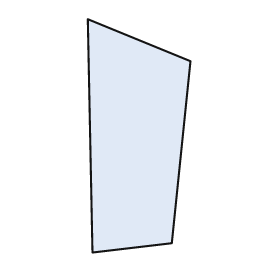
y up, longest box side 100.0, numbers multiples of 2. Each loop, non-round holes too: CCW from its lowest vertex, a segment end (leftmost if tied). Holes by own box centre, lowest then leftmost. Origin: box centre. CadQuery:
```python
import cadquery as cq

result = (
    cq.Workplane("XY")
    .moveTo(-20.0, -50.0)
    .lineTo(14.0, -46.0)
    .lineTo(22.0, 32.0)
    .lineTo(-22.0, 50.0)
    .close()
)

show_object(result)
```